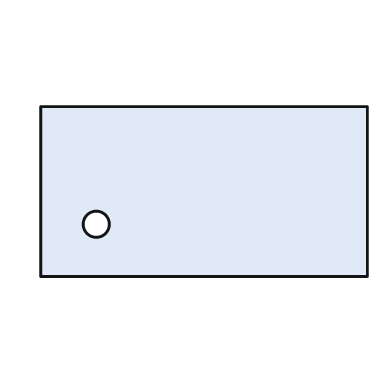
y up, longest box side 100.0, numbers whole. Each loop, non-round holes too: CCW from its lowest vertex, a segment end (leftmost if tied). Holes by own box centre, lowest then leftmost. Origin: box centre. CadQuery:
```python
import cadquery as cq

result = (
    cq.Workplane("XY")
    .moveTo(-50.0, -26.0)
    .lineTo(50.0, -26.0)
    .lineTo(50.0, 26.0)
    .lineTo(-50.0, 26.0)
    .close()
    .moveTo(-33.0, -10.0)
    .circle(4.0)
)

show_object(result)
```